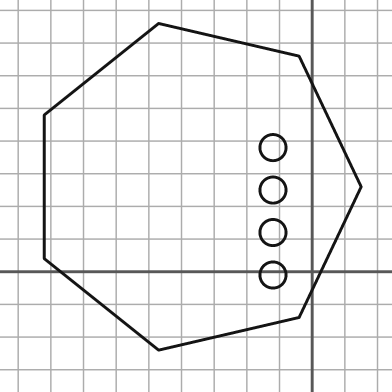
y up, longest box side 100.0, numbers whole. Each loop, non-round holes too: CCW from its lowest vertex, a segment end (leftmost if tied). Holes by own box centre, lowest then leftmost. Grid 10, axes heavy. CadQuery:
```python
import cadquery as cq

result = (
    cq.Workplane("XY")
    .moveTo(-47.0, -24.0)
    .lineTo(-4.0, -14.0)
    .lineTo(15.0, 26.0)
    .lineTo(-4.0, 66.0)
    .lineTo(-47.0, 76.0)
    .lineTo(-82.0, 48.0)
    .lineTo(-82.0, 4.0)
    .close()
    .moveTo(-12.0, -1.0)
    .circle(4.0)
    .moveTo(-12.0, 12.0)
    .circle(4.0)
    .moveTo(-12.0, 25.0)
    .circle(4.0)
    .moveTo(-12.0, 38.0)
    .circle(4.0)
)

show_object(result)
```